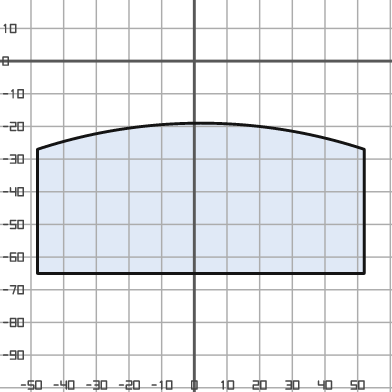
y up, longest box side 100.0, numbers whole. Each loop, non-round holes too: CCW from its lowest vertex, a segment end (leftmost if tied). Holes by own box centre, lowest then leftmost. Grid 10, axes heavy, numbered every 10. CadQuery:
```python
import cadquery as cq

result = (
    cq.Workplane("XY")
    .moveTo(-48.0, -65.0)
    .lineTo(52.0, -65.0)
    .lineTo(52.0, -27.0)
    .threePointArc((2.0, -19.0), (-48.0, -27.0))
    .close()
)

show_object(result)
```